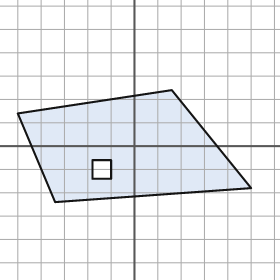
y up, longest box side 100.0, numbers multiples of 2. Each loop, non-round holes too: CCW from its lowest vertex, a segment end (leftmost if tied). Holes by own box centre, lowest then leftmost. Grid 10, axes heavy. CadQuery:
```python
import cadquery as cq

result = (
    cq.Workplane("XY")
    .moveTo(-34.0, -24.0)
    .lineTo(50.0, -18.0)
    .lineTo(16.0, 24.0)
    .lineTo(-50.0, 14.0)
    .close()
    .moveTo(-18.0, -14.0)
    .lineTo(-10.0, -14.0)
    .lineTo(-10.0, -6.0)
    .lineTo(-18.0, -6.0)
    .close()
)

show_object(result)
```